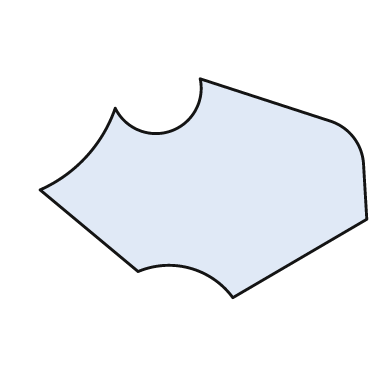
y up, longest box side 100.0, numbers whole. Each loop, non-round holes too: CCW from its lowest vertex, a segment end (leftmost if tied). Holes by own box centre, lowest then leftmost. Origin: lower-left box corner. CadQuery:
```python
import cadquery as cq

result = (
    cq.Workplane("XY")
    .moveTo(59.0, 0.0)
    .lineTo(100.0, 24.0)
    .lineTo(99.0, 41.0)
    .threePointArc((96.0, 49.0), (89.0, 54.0))
    .lineTo(49.0, 67.0)
    .threePointArc((40.0, 51.0), (23.0, 58.0))
    .threePointArc((14.0, 43.0), (0.0, 33.0))
    .lineTo(30.0, 8.0)
    .threePointArc((46.0, 9.0), (59.0, 0.0))
    .close()
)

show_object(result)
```